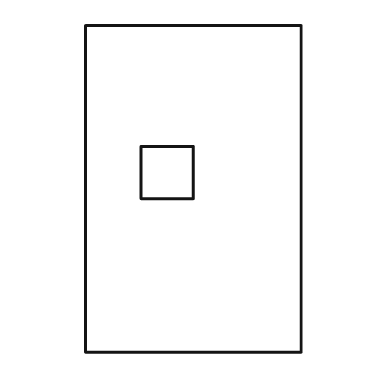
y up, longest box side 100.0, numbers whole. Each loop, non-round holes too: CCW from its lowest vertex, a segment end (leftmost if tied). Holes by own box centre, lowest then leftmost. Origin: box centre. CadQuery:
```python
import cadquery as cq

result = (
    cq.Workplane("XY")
    .moveTo(-33.0, -50.0)
    .lineTo(33.0, -50.0)
    .lineTo(33.0, 50.0)
    .lineTo(-33.0, 50.0)
    .close()
    .moveTo(-16.0, -3.0)
    .lineTo(0.0, -3.0)
    .lineTo(0.0, 13.0)
    .lineTo(-16.0, 13.0)
    .close()
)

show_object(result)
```